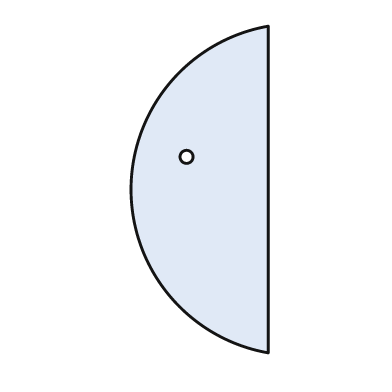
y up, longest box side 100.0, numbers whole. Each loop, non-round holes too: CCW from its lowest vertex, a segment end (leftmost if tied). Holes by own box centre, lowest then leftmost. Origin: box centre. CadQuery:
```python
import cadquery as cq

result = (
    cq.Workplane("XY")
    .moveTo(21.0, -50.0)
    .lineTo(21.0, 50.0)
    .threePointArc((-21.0, 0.0), (21.0, -50.0))
    .close()
    .moveTo(-4.0, 10.0)
    .circle(2.0)
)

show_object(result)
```